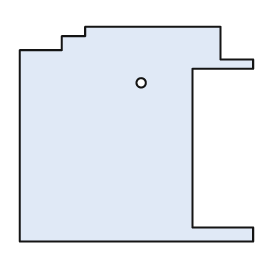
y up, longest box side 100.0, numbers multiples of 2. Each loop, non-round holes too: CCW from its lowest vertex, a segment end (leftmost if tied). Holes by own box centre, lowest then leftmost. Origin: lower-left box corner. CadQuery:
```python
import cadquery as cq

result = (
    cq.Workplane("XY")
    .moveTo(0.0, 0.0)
    .lineTo(100.0, 0.0)
    .lineTo(100.0, 6.0)
    .lineTo(74.0, 6.0)
    .lineTo(74.0, 74.0)
    .lineTo(100.0, 74.0)
    .lineTo(100.0, 78.0)
    .lineTo(86.0, 78.0)
    .lineTo(86.0, 92.0)
    .lineTo(28.0, 92.0)
    .lineTo(28.0, 88.0)
    .lineTo(18.0, 88.0)
    .lineTo(18.0, 82.0)
    .lineTo(0.0, 82.0)
    .close()
    .moveTo(52.0, 68.0)
    .circle(2.0)
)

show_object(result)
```